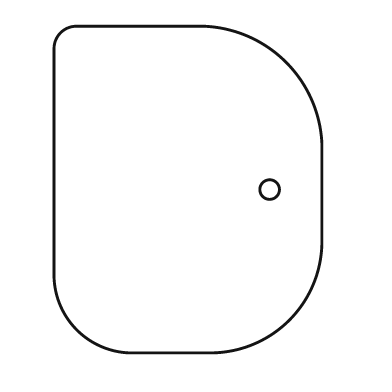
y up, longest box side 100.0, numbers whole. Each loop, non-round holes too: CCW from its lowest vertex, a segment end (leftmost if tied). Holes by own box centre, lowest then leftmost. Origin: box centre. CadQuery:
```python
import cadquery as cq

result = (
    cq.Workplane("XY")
    .moveTo(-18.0, -50.0)
    .lineTo(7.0, -50.0)
    .threePointArc((31.0, -40.0), (41.0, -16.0))
    .lineTo(41.0, 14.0)
    .threePointArc((30.0, 39.0), (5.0, 50.0))
    .lineTo(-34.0, 50.0)
    .threePointArc((-39.0, 48.0), (-41.0, 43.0))
    .lineTo(-41.0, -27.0)
    .threePointArc((-34.0, -43.0), (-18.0, -50.0))
    .close()
    .moveTo(25.0, 0.0)
    .circle(3.0)
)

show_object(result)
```